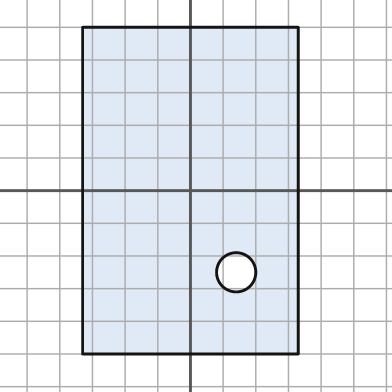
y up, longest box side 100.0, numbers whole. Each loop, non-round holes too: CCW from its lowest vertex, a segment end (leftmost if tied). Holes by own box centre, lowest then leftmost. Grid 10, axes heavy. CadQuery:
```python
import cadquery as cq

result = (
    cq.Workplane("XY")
    .moveTo(-33.0, -50.0)
    .lineTo(33.0, -50.0)
    .lineTo(33.0, 50.0)
    .lineTo(-33.0, 50.0)
    .close()
    .moveTo(14.0, -25.0)
    .circle(6.0)
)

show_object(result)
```